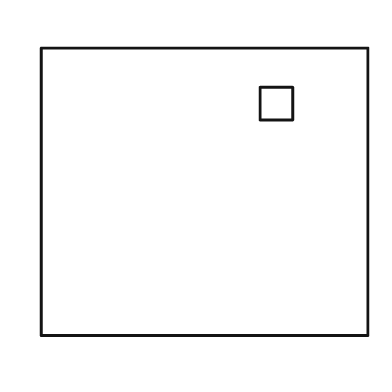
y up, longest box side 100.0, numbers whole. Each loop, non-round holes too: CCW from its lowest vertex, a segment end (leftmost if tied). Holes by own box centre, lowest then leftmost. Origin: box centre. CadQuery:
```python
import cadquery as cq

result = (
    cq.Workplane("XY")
    .moveTo(-50.0, -44.0)
    .lineTo(50.0, -44.0)
    .lineTo(50.0, 44.0)
    .lineTo(-50.0, 44.0)
    .close()
    .moveTo(17.0, 22.0)
    .lineTo(27.0, 22.0)
    .lineTo(27.0, 32.0)
    .lineTo(17.0, 32.0)
    .close()
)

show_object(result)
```